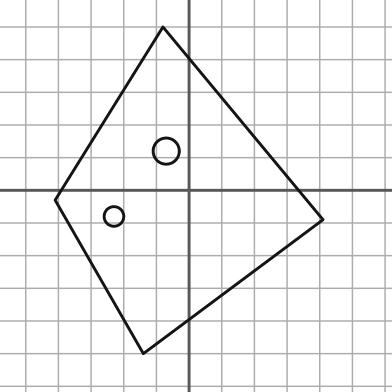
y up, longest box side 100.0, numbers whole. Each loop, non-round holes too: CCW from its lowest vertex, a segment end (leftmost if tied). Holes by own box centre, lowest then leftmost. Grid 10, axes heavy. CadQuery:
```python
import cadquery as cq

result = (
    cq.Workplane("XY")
    .moveTo(-14.0, -50.0)
    .lineTo(41.0, -9.0)
    .lineTo(-8.0, 50.0)
    .lineTo(-41.0, -3.0)
    .close()
    .moveTo(-23.0, -8.0)
    .circle(3.0)
    .moveTo(-7.0, 12.0)
    .circle(4.0)
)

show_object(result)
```